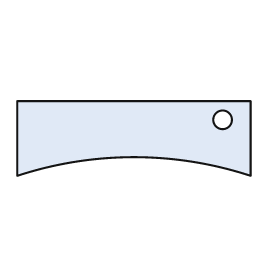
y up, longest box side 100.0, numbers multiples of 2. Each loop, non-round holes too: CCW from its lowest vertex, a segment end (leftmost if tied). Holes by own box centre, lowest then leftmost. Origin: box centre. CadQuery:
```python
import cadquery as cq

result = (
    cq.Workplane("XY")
    .moveTo(-50.0, -16.0)
    .threePointArc((0.0, -8.0), (50.0, -16.0))
    .lineTo(50.0, 16.0)
    .lineTo(-50.0, 16.0)
    .close()
    .moveTo(38.0, 8.0)
    .circle(4.0)
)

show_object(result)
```